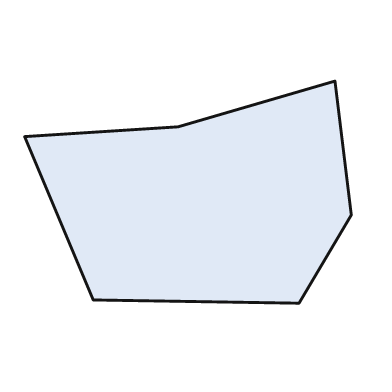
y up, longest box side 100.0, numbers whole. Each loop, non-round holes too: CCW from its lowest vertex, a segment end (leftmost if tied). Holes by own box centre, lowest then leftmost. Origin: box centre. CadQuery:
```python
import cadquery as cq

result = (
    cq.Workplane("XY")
    .moveTo(34.0, -34.0)
    .lineTo(50.0, -7.0)
    .lineTo(45.0, 34.0)
    .lineTo(-3.0, 20.0)
    .lineTo(-50.0, 17.0)
    .lineTo(-29.0, -33.0)
    .close()
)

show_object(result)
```